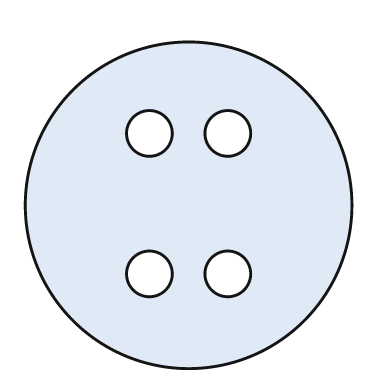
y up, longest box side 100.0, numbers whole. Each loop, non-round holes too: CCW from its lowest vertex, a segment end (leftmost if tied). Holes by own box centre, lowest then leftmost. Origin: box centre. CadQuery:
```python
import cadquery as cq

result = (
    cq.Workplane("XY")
    .moveTo(0.0, 0.0)
    .circle(50.0)
    .moveTo(-12.0, -21.0)
    .circle(7.0)
    .moveTo(12.0, -21.0)
    .circle(7.0)
    .moveTo(-12.0, 22.0)
    .circle(7.0)
    .moveTo(12.0, 22.0)
    .circle(7.0)
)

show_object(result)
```